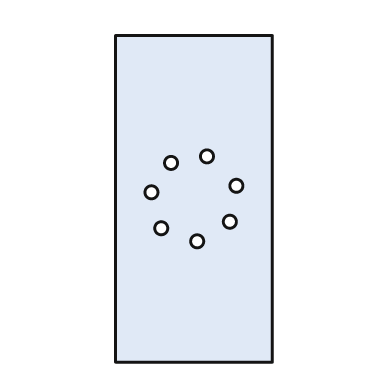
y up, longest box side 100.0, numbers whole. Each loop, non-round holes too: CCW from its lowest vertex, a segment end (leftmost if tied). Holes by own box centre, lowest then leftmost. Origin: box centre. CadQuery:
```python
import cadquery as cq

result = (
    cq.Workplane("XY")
    .moveTo(-24.0, -50.0)
    .lineTo(24.0, -50.0)
    .lineTo(24.0, 50.0)
    .lineTo(-24.0, 50.0)
    .close()
    .moveTo(1.0, -13.0)
    .circle(2.0)
    .moveTo(-10.0, -9.0)
    .circle(2.0)
    .moveTo(11.0, -7.0)
    .circle(2.0)
    .moveTo(-13.0, 2.0)
    .circle(2.0)
    .moveTo(13.0, 4.0)
    .circle(2.0)
    .moveTo(-7.0, 11.0)
    .circle(2.0)
    .moveTo(4.0, 13.0)
    .circle(2.0)
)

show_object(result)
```